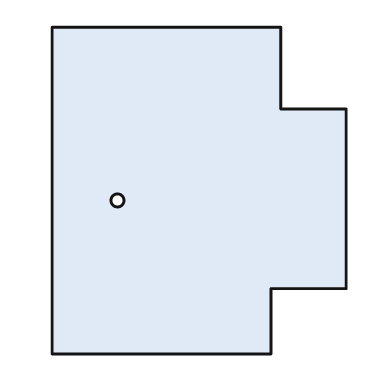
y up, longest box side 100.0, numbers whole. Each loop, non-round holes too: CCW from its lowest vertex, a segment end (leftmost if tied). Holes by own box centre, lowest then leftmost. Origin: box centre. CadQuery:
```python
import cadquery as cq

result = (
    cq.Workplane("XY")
    .moveTo(-45.0, -50.0)
    .lineTo(22.0, -50.0)
    .lineTo(22.0, -30.0)
    .lineTo(45.0, -30.0)
    .lineTo(45.0, 25.0)
    .lineTo(25.0, 25.0)
    .lineTo(25.0, 50.0)
    .lineTo(-45.0, 50.0)
    .close()
    .moveTo(-25.0, -3.0)
    .circle(2.0)
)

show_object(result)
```